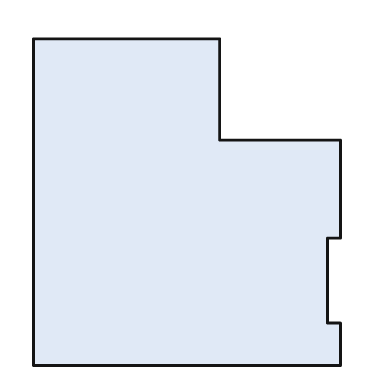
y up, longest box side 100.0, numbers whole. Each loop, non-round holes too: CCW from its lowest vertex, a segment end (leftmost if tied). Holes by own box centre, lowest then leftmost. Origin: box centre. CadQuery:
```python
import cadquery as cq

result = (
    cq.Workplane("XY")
    .moveTo(-47.0, -50.0)
    .lineTo(47.0, -50.0)
    .lineTo(47.0, -37.0)
    .lineTo(43.0, -37.0)
    .lineTo(43.0, -11.0)
    .lineTo(47.0, -11.0)
    .lineTo(47.0, 19.0)
    .lineTo(10.0, 19.0)
    .lineTo(10.0, 50.0)
    .lineTo(-47.0, 50.0)
    .close()
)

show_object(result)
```